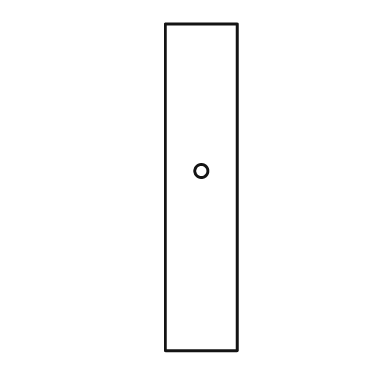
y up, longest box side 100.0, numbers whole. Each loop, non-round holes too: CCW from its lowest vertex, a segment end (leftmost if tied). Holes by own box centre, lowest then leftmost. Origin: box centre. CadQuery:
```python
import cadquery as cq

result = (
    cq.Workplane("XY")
    .moveTo(-11.0, -50.0)
    .lineTo(11.0, -50.0)
    .lineTo(11.0, 50.0)
    .lineTo(-11.0, 50.0)
    .close()
    .moveTo(0.0, 5.0)
    .circle(2.0)
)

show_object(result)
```